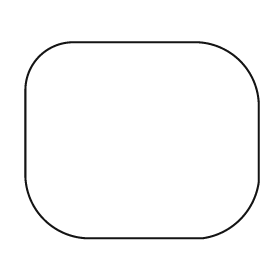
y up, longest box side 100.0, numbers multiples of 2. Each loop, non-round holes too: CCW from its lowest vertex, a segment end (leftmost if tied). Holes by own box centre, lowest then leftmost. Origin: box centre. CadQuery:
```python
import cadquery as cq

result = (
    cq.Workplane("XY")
    .moveTo(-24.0, -42.0)
    .lineTo(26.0, -42.0)
    .threePointArc((42.0, -34.0), (50.0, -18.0))
    .lineTo(50.0, 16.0)
    .threePointArc((42.0, 34.0), (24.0, 42.0))
    .lineTo(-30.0, 42.0)
    .threePointArc((-44.0, 36.0), (-50.0, 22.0))
    .lineTo(-50.0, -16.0)
    .threePointArc((-42.0, -34.0), (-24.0, -42.0))
    .close()
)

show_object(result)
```